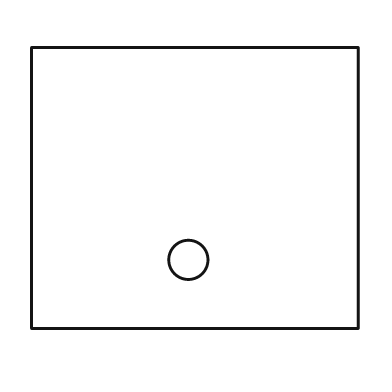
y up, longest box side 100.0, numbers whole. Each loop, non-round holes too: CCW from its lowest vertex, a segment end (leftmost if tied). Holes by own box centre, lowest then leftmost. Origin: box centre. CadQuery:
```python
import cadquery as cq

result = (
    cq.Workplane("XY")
    .moveTo(-50.0, -43.0)
    .lineTo(50.0, -43.0)
    .lineTo(50.0, 43.0)
    .lineTo(-50.0, 43.0)
    .close()
    .moveTo(-2.0, -22.0)
    .circle(6.0)
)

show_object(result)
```